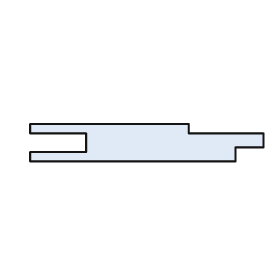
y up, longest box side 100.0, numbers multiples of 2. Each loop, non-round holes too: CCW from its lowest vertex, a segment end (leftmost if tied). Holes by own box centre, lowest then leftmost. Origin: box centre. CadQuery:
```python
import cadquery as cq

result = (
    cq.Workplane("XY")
    .moveTo(-50.0, -8.0)
    .lineTo(38.0, -8.0)
    .lineTo(38.0, -2.0)
    .lineTo(50.0, -2.0)
    .lineTo(50.0, 4.0)
    .lineTo(18.0, 4.0)
    .lineTo(18.0, 8.0)
    .lineTo(-50.0, 8.0)
    .lineTo(-50.0, 4.0)
    .lineTo(-26.0, 4.0)
    .lineTo(-26.0, -4.0)
    .lineTo(-50.0, -4.0)
    .close()
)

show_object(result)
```